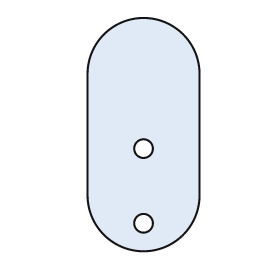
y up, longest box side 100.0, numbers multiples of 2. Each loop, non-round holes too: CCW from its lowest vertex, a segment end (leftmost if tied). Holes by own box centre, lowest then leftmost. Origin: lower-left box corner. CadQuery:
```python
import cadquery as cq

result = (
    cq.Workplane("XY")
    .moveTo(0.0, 24.0)
    .threePointArc((24.0, 0.0), (48.0, 24.0))
    .lineTo(48.0, 76.0)
    .threePointArc((24.0, 100.0), (0.0, 76.0))
    .close()
    .moveTo(24.0, 12.0)
    .circle(4.0)
    .moveTo(24.0, 44.0)
    .circle(4.0)
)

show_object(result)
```